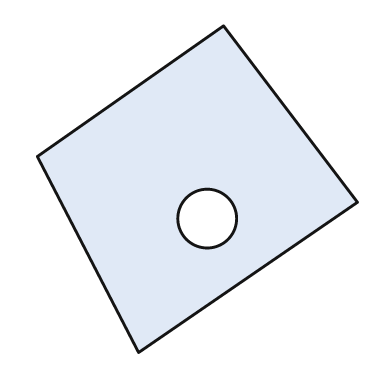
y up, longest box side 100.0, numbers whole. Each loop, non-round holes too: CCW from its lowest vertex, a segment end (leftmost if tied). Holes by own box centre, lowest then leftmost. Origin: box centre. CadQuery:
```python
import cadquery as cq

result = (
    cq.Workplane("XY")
    .moveTo(-18.0, -50.0)
    .lineTo(49.0, -4.0)
    .lineTo(8.0, 50.0)
    .lineTo(-49.0, 10.0)
    .close()
    .moveTo(3.0, -9.0)
    .circle(9.0)
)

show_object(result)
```